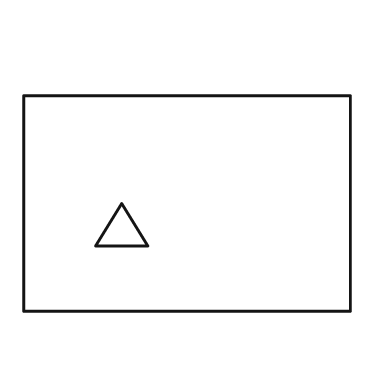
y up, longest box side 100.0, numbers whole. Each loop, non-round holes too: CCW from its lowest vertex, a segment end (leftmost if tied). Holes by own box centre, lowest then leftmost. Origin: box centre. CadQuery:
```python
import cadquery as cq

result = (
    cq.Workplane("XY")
    .moveTo(-50.0, -33.0)
    .lineTo(50.0, -33.0)
    .lineTo(50.0, 33.0)
    .lineTo(-50.0, 33.0)
    .close()
    .moveTo(-28.0, -13.0)
    .lineTo(-12.0, -13.0)
    .lineTo(-20.0, 0.0)
    .close()
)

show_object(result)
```